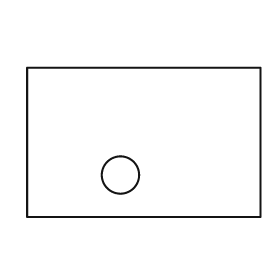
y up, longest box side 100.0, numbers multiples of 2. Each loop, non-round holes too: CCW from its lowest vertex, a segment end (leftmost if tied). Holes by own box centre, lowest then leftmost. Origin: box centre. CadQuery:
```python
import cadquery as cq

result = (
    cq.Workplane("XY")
    .moveTo(-50.0, -32.0)
    .lineTo(50.0, -32.0)
    .lineTo(50.0, 32.0)
    .lineTo(-50.0, 32.0)
    .close()
    .moveTo(-10.0, -14.0)
    .circle(8.0)
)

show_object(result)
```